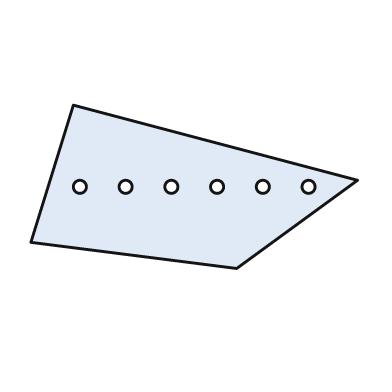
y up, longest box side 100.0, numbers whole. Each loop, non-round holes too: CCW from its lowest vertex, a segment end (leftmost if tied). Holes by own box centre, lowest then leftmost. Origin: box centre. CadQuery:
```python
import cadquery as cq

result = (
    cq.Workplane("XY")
    .moveTo(13.0, -25.0)
    .lineTo(50.0, 2.0)
    .lineTo(-37.0, 25.0)
    .lineTo(-50.0, -17.0)
    .close()
    .moveTo(-35.0, 0.0)
    .circle(2.0)
    .moveTo(-21.0, 0.0)
    .circle(2.0)
    .moveTo(-7.0, 0.0)
    .circle(2.0)
    .moveTo(7.0, 0.0)
    .circle(2.0)
    .moveTo(21.0, 0.0)
    .circle(2.0)
    .moveTo(35.0, 0.0)
    .circle(2.0)
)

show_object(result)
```